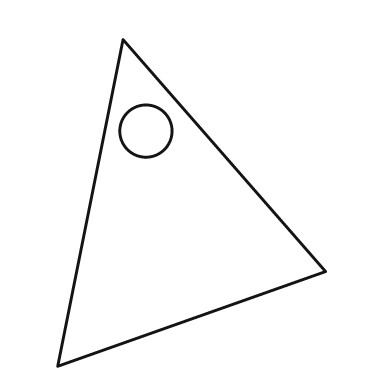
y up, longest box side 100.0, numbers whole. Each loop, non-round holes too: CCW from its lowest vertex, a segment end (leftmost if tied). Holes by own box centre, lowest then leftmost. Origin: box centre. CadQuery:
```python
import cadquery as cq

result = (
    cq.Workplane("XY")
    .moveTo(-41.0, -50.0)
    .lineTo(41.0, -21.0)
    .lineTo(-21.0, 50.0)
    .close()
    .moveTo(-14.0, 22.0)
    .circle(8.0)
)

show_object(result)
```